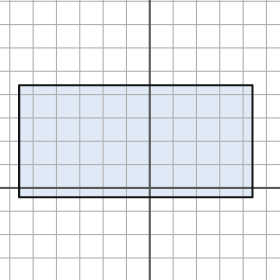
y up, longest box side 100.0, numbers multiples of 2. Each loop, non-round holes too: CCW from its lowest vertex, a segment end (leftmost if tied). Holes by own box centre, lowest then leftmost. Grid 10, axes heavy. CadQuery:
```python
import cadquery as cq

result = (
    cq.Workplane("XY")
    .moveTo(-56.0, -4.0)
    .lineTo(44.0, -4.0)
    .lineTo(44.0, 44.0)
    .lineTo(-56.0, 44.0)
    .close()
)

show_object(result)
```